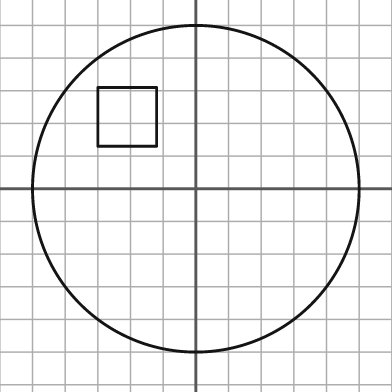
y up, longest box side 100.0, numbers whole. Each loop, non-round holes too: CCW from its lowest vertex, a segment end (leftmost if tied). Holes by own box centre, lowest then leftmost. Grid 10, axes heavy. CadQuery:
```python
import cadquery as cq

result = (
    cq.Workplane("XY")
    .moveTo(0.0, 0.0)
    .circle(50.0)
    .moveTo(-30.0, 13.0)
    .lineTo(-12.0, 13.0)
    .lineTo(-12.0, 31.0)
    .lineTo(-30.0, 31.0)
    .close()
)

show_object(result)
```